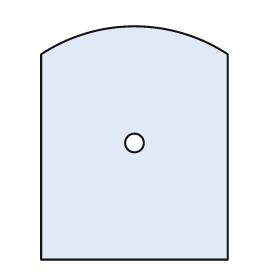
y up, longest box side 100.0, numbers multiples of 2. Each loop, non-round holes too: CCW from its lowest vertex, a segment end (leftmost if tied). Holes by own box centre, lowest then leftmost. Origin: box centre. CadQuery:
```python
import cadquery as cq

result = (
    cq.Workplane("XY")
    .moveTo(-40.0, -50.0)
    .lineTo(40.0, -50.0)
    .lineTo(40.0, 38.0)
    .threePointArc((0.0, 50.0), (-40.0, 38.0))
    .close()
    .moveTo(0.0, 0.0)
    .circle(4.0)
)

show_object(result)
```